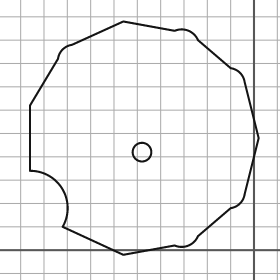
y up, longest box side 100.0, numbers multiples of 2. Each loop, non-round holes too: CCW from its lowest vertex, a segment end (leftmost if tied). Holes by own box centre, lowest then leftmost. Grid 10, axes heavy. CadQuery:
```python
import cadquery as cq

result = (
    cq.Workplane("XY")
    .moveTo(-56.0, -2.0)
    .lineTo(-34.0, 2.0)
    .threePointArc((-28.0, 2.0), (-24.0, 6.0))
    .lineTo(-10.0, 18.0)
    .threePointArc((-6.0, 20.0), (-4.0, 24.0))
    .lineTo(2.0, 48.0)
    .lineTo(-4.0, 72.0)
    .threePointArc((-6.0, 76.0), (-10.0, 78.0))
    .lineTo(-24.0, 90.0)
    .threePointArc((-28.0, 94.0), (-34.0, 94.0))
    .lineTo(-56.0, 98.0)
    .lineTo(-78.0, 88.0)
    .threePointArc((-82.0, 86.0), (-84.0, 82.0))
    .lineTo(-96.0, 62.0)
    .lineTo(-96.0, 34.0)
    .threePointArc((-82.0, 26.0), (-82.0, 10.0))
    .close()
    .moveTo(-48.0, 42.0)
    .circle(4.0)
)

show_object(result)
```